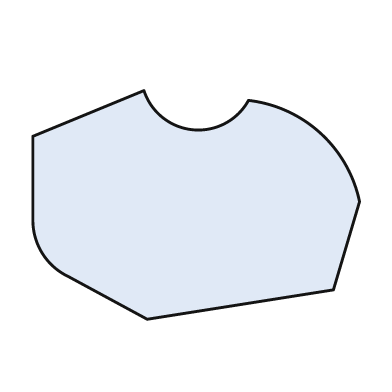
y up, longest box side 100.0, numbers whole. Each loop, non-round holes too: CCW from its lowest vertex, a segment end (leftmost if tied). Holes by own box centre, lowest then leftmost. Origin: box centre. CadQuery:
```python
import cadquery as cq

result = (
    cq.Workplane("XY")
    .moveTo(-15.0, -35.0)
    .lineTo(42.0, -26.0)
    .lineTo(50.0, 1.0)
    .threePointArc((38.0, 22.0), (16.0, 32.0))
    .threePointArc((-1.0, 23.0), (-16.0, 35.0))
    .lineTo(-50.0, 21.0)
    .lineTo(-50.0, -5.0)
    .threePointArc((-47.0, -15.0), (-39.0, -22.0))
    .close()
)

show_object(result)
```